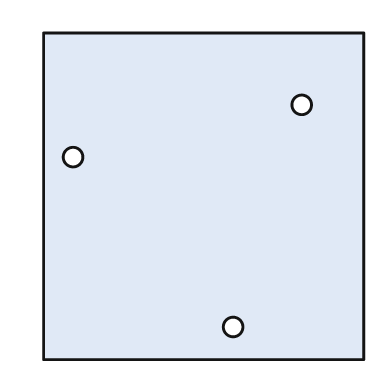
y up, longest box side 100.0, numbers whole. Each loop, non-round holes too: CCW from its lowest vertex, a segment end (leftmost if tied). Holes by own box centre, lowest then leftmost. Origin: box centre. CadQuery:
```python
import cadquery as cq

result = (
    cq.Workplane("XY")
    .moveTo(-49.0, -50.0)
    .lineTo(49.0, -50.0)
    .lineTo(49.0, 50.0)
    .lineTo(-49.0, 50.0)
    .close()
    .moveTo(9.0, -40.0)
    .circle(3.0)
    .moveTo(-40.0, 12.0)
    .circle(3.0)
    .moveTo(30.0, 28.0)
    .circle(3.0)
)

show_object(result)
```